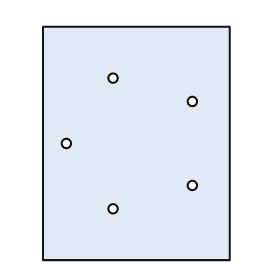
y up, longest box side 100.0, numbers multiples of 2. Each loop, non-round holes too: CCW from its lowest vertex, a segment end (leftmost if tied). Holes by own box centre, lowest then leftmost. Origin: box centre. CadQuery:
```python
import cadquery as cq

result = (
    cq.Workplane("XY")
    .moveTo(-40.0, -50.0)
    .lineTo(40.0, -50.0)
    .lineTo(40.0, 50.0)
    .lineTo(-40.0, 50.0)
    .close()
    .moveTo(-10.0, -28.0)
    .circle(2.0)
    .moveTo(24.0, -18.0)
    .circle(2.0)
    .moveTo(-30.0, 0.0)
    .circle(2.0)
    .moveTo(24.0, 18.0)
    .circle(2.0)
    .moveTo(-10.0, 28.0)
    .circle(2.0)
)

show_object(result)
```